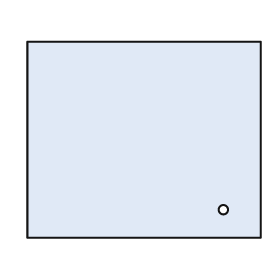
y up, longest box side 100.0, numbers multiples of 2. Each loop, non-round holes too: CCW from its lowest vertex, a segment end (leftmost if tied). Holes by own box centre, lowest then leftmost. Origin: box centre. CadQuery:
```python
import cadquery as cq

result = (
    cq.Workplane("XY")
    .moveTo(-50.0, -42.0)
    .lineTo(50.0, -42.0)
    .lineTo(50.0, 42.0)
    .lineTo(-50.0, 42.0)
    .close()
    .moveTo(34.0, -30.0)
    .circle(2.0)
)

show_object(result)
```